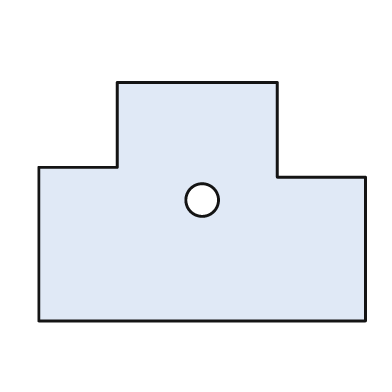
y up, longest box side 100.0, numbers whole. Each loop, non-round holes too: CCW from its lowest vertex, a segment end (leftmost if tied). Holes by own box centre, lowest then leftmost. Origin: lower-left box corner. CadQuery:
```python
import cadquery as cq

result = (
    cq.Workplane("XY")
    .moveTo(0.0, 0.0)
    .lineTo(100.0, 0.0)
    .lineTo(100.0, 44.0)
    .lineTo(73.0, 44.0)
    .lineTo(73.0, 73.0)
    .lineTo(24.0, 73.0)
    .lineTo(24.0, 47.0)
    .lineTo(0.0, 47.0)
    .close()
    .moveTo(50.0, 37.0)
    .circle(5.0)
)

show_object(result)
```